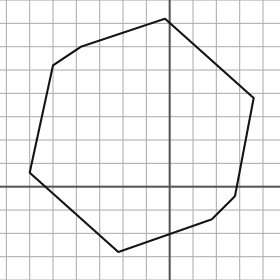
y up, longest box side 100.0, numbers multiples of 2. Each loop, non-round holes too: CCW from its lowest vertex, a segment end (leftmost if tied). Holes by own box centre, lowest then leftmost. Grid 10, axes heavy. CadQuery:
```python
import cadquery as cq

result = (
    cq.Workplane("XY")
    .moveTo(-22.0, -28.0)
    .lineTo(18.0, -14.0)
    .lineTo(28.0, -4.0)
    .lineTo(36.0, 38.0)
    .lineTo(-2.0, 72.0)
    .lineTo(-38.0, 60.0)
    .lineTo(-50.0, 52.0)
    .lineTo(-60.0, 6.0)
    .close()
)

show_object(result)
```